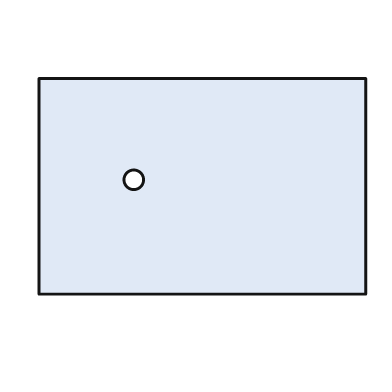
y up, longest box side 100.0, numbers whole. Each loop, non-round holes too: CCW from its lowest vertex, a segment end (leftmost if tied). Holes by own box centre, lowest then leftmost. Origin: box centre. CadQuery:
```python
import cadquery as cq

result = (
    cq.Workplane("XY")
    .moveTo(-50.0, -33.0)
    .lineTo(50.0, -33.0)
    .lineTo(50.0, 33.0)
    .lineTo(-50.0, 33.0)
    .close()
    .moveTo(-21.0, 2.0)
    .circle(3.0)
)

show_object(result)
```